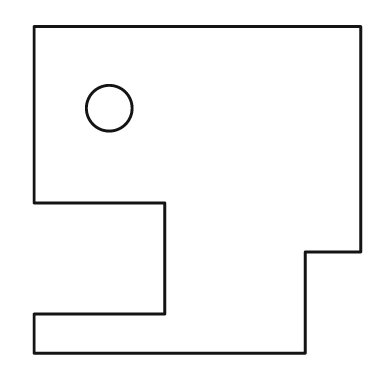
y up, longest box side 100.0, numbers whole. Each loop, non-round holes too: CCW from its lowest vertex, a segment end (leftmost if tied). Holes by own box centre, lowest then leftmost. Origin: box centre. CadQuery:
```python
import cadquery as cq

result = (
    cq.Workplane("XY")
    .moveTo(-50.0, -50.0)
    .lineTo(33.0, -50.0)
    .lineTo(33.0, -19.0)
    .lineTo(50.0, -19.0)
    .lineTo(50.0, 50.0)
    .lineTo(-50.0, 50.0)
    .lineTo(-50.0, -4.0)
    .lineTo(-10.0, -4.0)
    .lineTo(-10.0, -38.0)
    .lineTo(-50.0, -38.0)
    .close()
    .moveTo(-27.0, 25.0)
    .circle(7.0)
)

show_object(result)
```